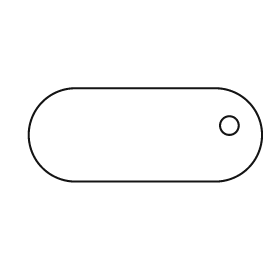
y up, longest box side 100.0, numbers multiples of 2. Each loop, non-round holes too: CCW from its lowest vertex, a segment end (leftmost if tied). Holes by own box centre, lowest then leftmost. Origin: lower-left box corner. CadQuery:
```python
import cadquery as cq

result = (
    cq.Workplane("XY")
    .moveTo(20.0, 0.0)
    .lineTo(80.0, 0.0)
    .threePointArc((100.0, 20.0), (80.0, 40.0))
    .lineTo(20.0, 40.0)
    .threePointArc((0.0, 20.0), (20.0, 0.0))
    .close()
    .moveTo(86.0, 24.0)
    .circle(4.0)
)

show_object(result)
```